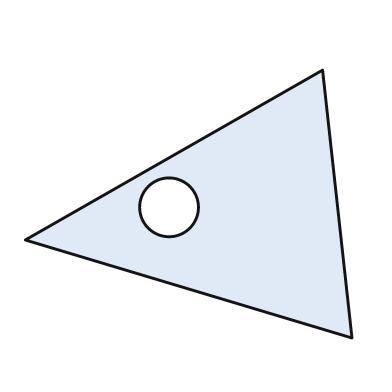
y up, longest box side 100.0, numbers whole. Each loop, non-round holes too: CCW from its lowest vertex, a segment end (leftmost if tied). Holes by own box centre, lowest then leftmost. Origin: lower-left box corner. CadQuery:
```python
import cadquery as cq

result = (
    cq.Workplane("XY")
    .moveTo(100.0, 0.0)
    .lineTo(91.0, 82.0)
    .lineTo(0.0, 30.0)
    .close()
    .moveTo(44.0, 40.0)
    .circle(9.0)
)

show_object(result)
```